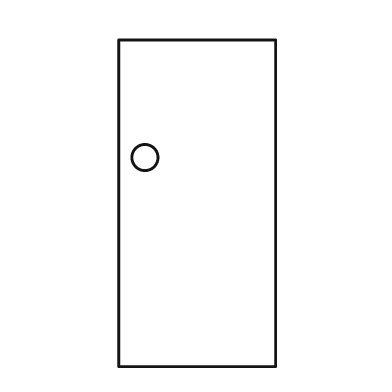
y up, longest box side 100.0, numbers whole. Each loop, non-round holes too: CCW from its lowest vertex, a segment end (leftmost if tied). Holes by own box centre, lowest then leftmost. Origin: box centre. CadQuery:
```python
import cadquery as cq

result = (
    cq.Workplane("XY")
    .moveTo(-24.0, -50.0)
    .lineTo(24.0, -50.0)
    .lineTo(24.0, 50.0)
    .lineTo(-24.0, 50.0)
    .close()
    .moveTo(-16.0, 14.0)
    .circle(4.0)
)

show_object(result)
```